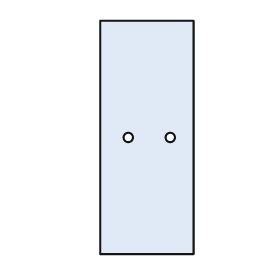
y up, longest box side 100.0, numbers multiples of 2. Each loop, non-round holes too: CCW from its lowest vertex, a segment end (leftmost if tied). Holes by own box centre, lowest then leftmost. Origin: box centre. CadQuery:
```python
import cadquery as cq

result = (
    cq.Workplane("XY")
    .moveTo(-20.0, -50.0)
    .lineTo(20.0, -50.0)
    .lineTo(20.0, 50.0)
    .lineTo(-20.0, 50.0)
    .close()
    .moveTo(-8.0, 0.0)
    .circle(2.0)
    .moveTo(10.0, 0.0)
    .circle(2.0)
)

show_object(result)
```